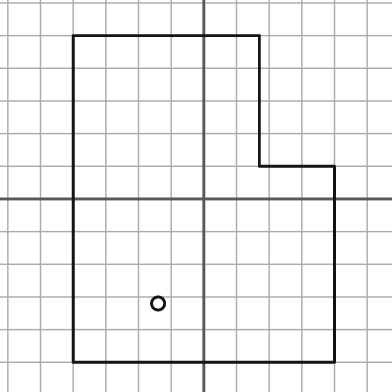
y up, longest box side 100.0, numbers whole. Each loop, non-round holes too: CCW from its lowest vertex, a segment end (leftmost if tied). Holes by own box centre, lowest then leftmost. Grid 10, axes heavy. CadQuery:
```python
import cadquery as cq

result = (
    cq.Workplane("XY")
    .moveTo(-40.0, -50.0)
    .lineTo(40.0, -50.0)
    .lineTo(40.0, 10.0)
    .lineTo(17.0, 10.0)
    .lineTo(17.0, 50.0)
    .lineTo(-40.0, 50.0)
    .close()
    .moveTo(-14.0, -32.0)
    .circle(2.0)
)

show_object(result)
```